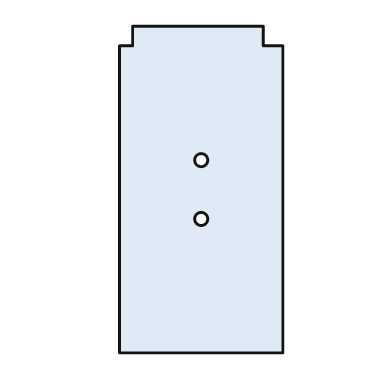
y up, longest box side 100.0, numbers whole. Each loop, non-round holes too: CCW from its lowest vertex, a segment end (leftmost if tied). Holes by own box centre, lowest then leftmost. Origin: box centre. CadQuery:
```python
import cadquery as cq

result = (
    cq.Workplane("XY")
    .moveTo(-25.0, -50.0)
    .lineTo(25.0, -50.0)
    .lineTo(25.0, 44.0)
    .lineTo(19.0, 44.0)
    .lineTo(19.0, 50.0)
    .lineTo(-21.0, 50.0)
    .lineTo(-21.0, 44.0)
    .lineTo(-25.0, 44.0)
    .close()
    .moveTo(0.0, -9.0)
    .circle(2.0)
    .moveTo(0.0, 9.0)
    .circle(2.0)
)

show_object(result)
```